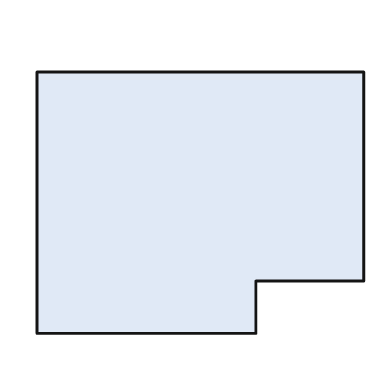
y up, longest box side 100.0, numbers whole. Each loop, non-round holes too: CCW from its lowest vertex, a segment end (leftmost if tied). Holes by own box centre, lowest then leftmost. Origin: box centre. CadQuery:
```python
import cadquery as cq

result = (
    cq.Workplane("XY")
    .moveTo(-50.0, -40.0)
    .lineTo(17.0, -40.0)
    .lineTo(17.0, -24.0)
    .lineTo(50.0, -24.0)
    .lineTo(50.0, 40.0)
    .lineTo(-50.0, 40.0)
    .close()
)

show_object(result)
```